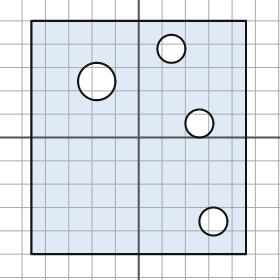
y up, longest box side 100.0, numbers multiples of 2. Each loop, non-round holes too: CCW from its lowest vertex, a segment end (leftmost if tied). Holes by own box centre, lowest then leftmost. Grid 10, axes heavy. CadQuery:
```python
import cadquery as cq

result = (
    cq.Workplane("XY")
    .moveTo(-46.0, -50.0)
    .lineTo(46.0, -50.0)
    .lineTo(46.0, 50.0)
    .lineTo(-46.0, 50.0)
    .close()
    .moveTo(32.0, -36.0)
    .circle(6.0)
    .moveTo(26.0, 6.0)
    .circle(6.0)
    .moveTo(-18.0, 24.0)
    .circle(8.0)
    .moveTo(14.0, 38.0)
    .circle(6.0)
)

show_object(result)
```